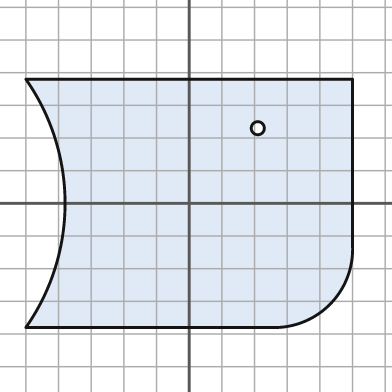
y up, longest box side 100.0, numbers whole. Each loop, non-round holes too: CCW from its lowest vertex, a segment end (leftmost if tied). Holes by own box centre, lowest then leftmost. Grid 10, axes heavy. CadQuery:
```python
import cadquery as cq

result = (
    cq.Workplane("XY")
    .moveTo(-50.0, -38.0)
    .lineTo(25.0, -38.0)
    .threePointArc((43.0, -31.0), (50.0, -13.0))
    .lineTo(50.0, 38.0)
    .lineTo(-50.0, 38.0)
    .threePointArc((-38.0, 0.0), (-50.0, -38.0))
    .close()
    .moveTo(21.0, 23.0)
    .circle(2.0)
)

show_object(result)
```